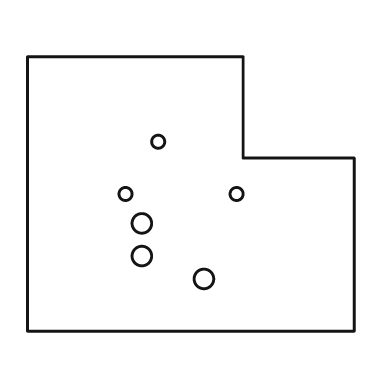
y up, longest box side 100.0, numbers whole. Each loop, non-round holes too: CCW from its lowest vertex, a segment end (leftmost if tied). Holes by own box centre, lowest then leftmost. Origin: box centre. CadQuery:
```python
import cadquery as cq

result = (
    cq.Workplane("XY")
    .moveTo(-50.0, -42.0)
    .lineTo(50.0, -42.0)
    .lineTo(50.0, 11.0)
    .lineTo(16.0, 11.0)
    .lineTo(16.0, 42.0)
    .lineTo(-50.0, 42.0)
    .close()
    .moveTo(4.0, -26.0)
    .circle(3.0)
    .moveTo(-15.0, -19.0)
    .circle(3.0)
    .moveTo(-15.0, -9.0)
    .circle(3.0)
    .moveTo(-20.0, 0.0)
    .circle(2.0)
    .moveTo(14.0, 0.0)
    .circle(2.0)
    .moveTo(-10.0, 16.0)
    .circle(2.0)
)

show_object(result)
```